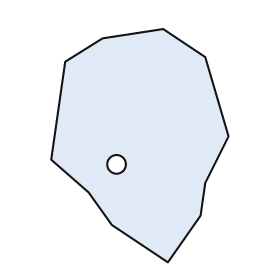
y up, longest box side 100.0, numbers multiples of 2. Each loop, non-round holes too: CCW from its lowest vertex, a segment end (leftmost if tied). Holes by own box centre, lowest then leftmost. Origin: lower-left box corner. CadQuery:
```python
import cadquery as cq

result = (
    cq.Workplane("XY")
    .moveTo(50.0, 0.0)
    .lineTo(64.0, 20.0)
    .lineTo(66.0, 34.0)
    .lineTo(76.0, 54.0)
    .lineTo(66.0, 88.0)
    .lineTo(48.0, 100.0)
    .lineTo(22.0, 96.0)
    .lineTo(6.0, 86.0)
    .lineTo(0.0, 44.0)
    .lineTo(16.0, 30.0)
    .lineTo(26.0, 16.0)
    .close()
    .moveTo(28.0, 42.0)
    .circle(4.0)
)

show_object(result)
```